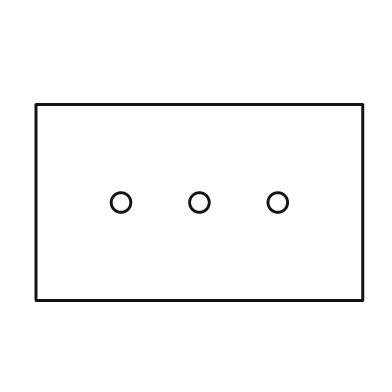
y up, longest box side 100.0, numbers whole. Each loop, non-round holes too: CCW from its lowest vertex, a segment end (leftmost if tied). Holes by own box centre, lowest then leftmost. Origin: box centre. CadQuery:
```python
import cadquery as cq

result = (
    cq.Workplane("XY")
    .moveTo(-50.0, -30.0)
    .lineTo(50.0, -30.0)
    .lineTo(50.0, 30.0)
    .lineTo(-50.0, 30.0)
    .close()
    .moveTo(-24.0, 0.0)
    .circle(3.0)
    .moveTo(0.0, 0.0)
    .circle(3.0)
    .moveTo(24.0, 0.0)
    .circle(3.0)
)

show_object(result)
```